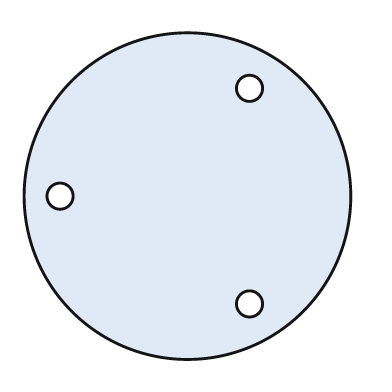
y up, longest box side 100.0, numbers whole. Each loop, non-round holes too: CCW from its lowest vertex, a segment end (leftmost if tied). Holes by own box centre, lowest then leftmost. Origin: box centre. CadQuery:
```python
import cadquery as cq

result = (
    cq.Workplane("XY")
    .moveTo(0.0, 0.0)
    .circle(50.0)
    .moveTo(19.0, -33.0)
    .circle(4.0)
    .moveTo(-39.0, 0.0)
    .circle(4.0)
    .moveTo(19.0, 33.0)
    .circle(4.0)
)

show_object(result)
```